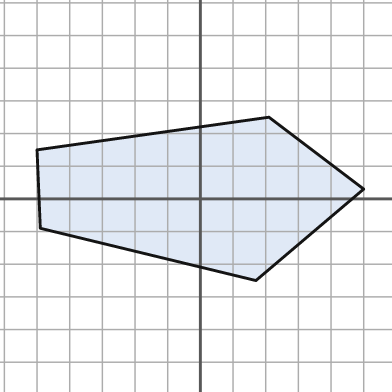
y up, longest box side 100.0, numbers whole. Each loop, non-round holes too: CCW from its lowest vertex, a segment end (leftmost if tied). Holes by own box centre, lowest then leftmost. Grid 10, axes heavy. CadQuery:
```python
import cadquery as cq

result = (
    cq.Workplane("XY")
    .moveTo(17.0, -25.0)
    .lineTo(50.0, 3.0)
    .lineTo(21.0, 25.0)
    .lineTo(-50.0, 15.0)
    .lineTo(-49.0, -9.0)
    .close()
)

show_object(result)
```